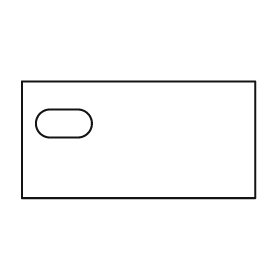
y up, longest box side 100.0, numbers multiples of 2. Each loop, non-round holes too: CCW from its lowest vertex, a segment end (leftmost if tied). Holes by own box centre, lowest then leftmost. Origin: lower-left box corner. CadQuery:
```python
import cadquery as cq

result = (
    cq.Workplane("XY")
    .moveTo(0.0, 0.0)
    .lineTo(100.0, 0.0)
    .lineTo(100.0, 50.0)
    .lineTo(0.0, 50.0)
    .close()
    .moveTo(12.0, 26.0)
    .lineTo(24.0, 26.0)
    .threePointArc((30.0, 32.0), (24.0, 38.0))
    .lineTo(12.0, 38.0)
    .threePointArc((6.0, 32.0), (12.0, 26.0))
    .close()
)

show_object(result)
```